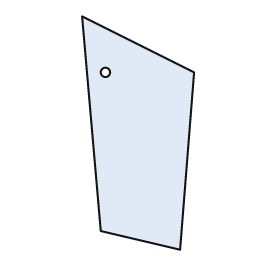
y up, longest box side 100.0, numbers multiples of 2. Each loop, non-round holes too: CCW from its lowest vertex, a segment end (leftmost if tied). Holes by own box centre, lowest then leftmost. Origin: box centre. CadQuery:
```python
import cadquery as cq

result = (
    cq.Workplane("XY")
    .moveTo(18.0, -50.0)
    .lineTo(24.0, 26.0)
    .lineTo(-24.0, 50.0)
    .lineTo(-16.0, -42.0)
    .close()
    .moveTo(-14.0, 26.0)
    .circle(2.0)
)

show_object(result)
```